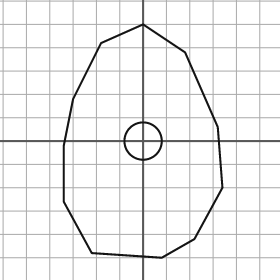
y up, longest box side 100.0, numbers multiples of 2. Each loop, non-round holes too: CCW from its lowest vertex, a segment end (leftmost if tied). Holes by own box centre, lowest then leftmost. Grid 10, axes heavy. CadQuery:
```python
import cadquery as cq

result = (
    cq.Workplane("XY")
    .moveTo(8.0, -50.0)
    .lineTo(22.0, -42.0)
    .lineTo(34.0, -20.0)
    .lineTo(32.0, 6.0)
    .lineTo(18.0, 38.0)
    .lineTo(0.0, 50.0)
    .lineTo(-18.0, 42.0)
    .lineTo(-30.0, 18.0)
    .lineTo(-34.0, -2.0)
    .lineTo(-34.0, -26.0)
    .lineTo(-22.0, -48.0)
    .close()
    .moveTo(0.0, 0.0)
    .circle(8.0)
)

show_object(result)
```